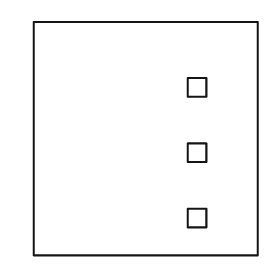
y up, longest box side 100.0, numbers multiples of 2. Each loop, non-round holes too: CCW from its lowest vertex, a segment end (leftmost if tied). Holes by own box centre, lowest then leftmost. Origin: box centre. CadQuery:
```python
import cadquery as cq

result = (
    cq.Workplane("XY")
    .moveTo(-48.0, -50.0)
    .lineTo(48.0, -50.0)
    .lineTo(48.0, 50.0)
    .lineTo(-48.0, 50.0)
    .close()
    .moveTo(18.0, -38.0)
    .lineTo(26.0, -38.0)
    .lineTo(26.0, -30.0)
    .lineTo(18.0, -30.0)
    .close()
    .moveTo(18.0, -10.0)
    .lineTo(26.0, -10.0)
    .lineTo(26.0, -2.0)
    .lineTo(18.0, -2.0)
    .close()
    .moveTo(18.0, 18.0)
    .lineTo(26.0, 18.0)
    .lineTo(26.0, 26.0)
    .lineTo(18.0, 26.0)
    .close()
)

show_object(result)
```